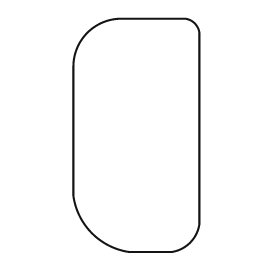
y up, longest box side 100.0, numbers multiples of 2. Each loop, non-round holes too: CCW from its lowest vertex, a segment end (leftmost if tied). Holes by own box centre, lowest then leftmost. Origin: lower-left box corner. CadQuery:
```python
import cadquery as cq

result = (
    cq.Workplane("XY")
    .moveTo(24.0, 0.0)
    .lineTo(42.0, 0.0)
    .threePointArc((50.0, 4.0), (54.0, 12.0))
    .lineTo(54.0, 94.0)
    .threePointArc((52.0, 98.0), (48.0, 100.0))
    .lineTo(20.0, 100.0)
    .threePointArc((6.0, 94.0), (0.0, 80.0))
    .lineTo(0.0, 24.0)
    .threePointArc((8.0, 8.0), (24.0, 0.0))
    .close()
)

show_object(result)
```